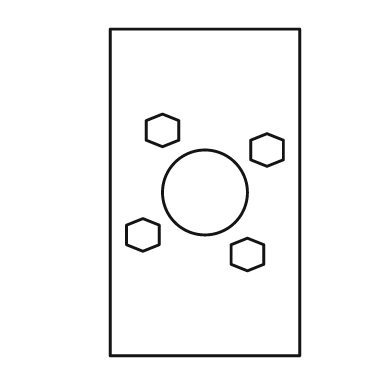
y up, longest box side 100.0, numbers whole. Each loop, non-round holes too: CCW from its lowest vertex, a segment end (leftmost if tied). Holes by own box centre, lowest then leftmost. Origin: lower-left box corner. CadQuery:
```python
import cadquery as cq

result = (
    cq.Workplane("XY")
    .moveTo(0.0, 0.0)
    .lineTo(58.0, 0.0)
    .lineTo(58.0, 100.0)
    .lineTo(0.0, 100.0)
    .close()
    .moveTo(42.0, 26.0)
    .lineTo(47.0, 28.0)
    .lineTo(47.0, 34.0)
    .lineTo(42.0, 36.0)
    .lineTo(37.0, 34.0)
    .lineTo(37.0, 28.0)
    .close()
    .moveTo(10.0, 32.0)
    .lineTo(15.0, 34.0)
    .lineTo(15.0, 40.0)
    .lineTo(10.0, 42.0)
    .lineTo(5.0, 40.0)
    .lineTo(5.0, 34.0)
    .close()
    .moveTo(29.0, 50.0)
    .circle(13.0)
    .moveTo(48.0, 58.0)
    .lineTo(53.0, 60.0)
    .lineTo(53.0, 66.0)
    .lineTo(48.0, 68.0)
    .lineTo(43.0, 66.0)
    .lineTo(43.0, 60.0)
    .close()
    .moveTo(16.0, 64.0)
    .lineTo(21.0, 66.0)
    .lineTo(21.0, 72.0)
    .lineTo(16.0, 74.0)
    .lineTo(11.0, 72.0)
    .lineTo(11.0, 66.0)
    .close()
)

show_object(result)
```